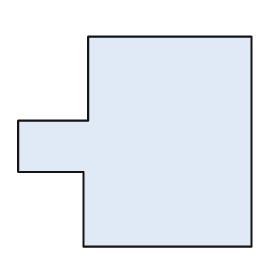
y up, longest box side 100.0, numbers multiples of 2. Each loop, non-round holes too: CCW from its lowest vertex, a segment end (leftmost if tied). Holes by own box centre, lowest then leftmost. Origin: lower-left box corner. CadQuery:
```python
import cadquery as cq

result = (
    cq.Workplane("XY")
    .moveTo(28.0, 0.0)
    .lineTo(100.0, 0.0)
    .lineTo(100.0, 90.0)
    .lineTo(30.0, 90.0)
    .lineTo(30.0, 54.0)
    .lineTo(0.0, 54.0)
    .lineTo(0.0, 32.0)
    .lineTo(28.0, 32.0)
    .close()
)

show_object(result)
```